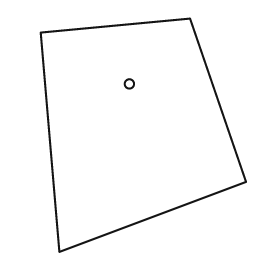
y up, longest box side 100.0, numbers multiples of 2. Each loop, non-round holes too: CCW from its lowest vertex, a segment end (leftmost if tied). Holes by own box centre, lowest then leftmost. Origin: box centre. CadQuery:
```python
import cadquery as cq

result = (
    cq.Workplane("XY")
    .moveTo(-36.0, -50.0)
    .lineTo(44.0, -20.0)
    .lineTo(20.0, 50.0)
    .lineTo(-44.0, 44.0)
    .close()
    .moveTo(-6.0, 22.0)
    .circle(2.0)
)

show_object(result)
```